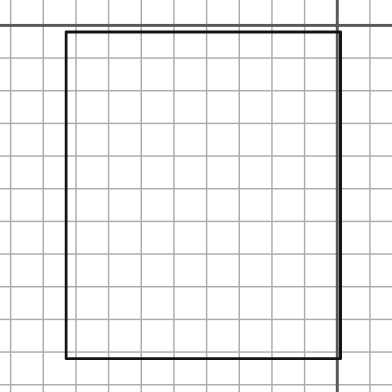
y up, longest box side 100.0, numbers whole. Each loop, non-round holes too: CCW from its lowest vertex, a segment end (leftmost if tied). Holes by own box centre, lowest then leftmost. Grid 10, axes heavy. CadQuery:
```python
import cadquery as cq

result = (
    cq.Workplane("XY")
    .moveTo(-83.0, -102.0)
    .lineTo(1.0, -102.0)
    .lineTo(1.0, -2.0)
    .lineTo(-83.0, -2.0)
    .close()
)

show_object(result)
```